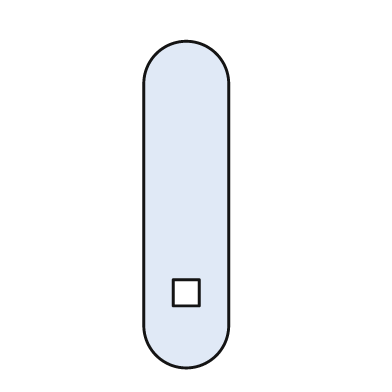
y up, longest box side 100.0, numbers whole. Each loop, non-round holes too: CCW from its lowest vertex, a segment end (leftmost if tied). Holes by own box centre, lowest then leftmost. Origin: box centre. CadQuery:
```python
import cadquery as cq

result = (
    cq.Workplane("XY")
    .moveTo(-13.0, -37.0)
    .threePointArc((0.0, -50.0), (13.0, -37.0))
    .lineTo(13.0, 37.0)
    .threePointArc((0.0, 50.0), (-13.0, 37.0))
    .close()
    .moveTo(-4.0, -31.0)
    .lineTo(4.0, -31.0)
    .lineTo(4.0, -23.0)
    .lineTo(-4.0, -23.0)
    .close()
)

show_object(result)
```